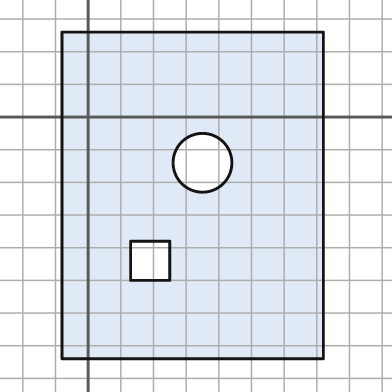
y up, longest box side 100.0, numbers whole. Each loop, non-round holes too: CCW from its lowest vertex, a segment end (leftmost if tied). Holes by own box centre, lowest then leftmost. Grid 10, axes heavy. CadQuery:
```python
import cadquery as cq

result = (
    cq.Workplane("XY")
    .moveTo(-8.0, -74.0)
    .lineTo(72.0, -74.0)
    .lineTo(72.0, 26.0)
    .lineTo(-8.0, 26.0)
    .close()
    .moveTo(13.0, -50.0)
    .lineTo(25.0, -50.0)
    .lineTo(25.0, -38.0)
    .lineTo(13.0, -38.0)
    .close()
    .moveTo(35.0, -14.0)
    .circle(9.0)
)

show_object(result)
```